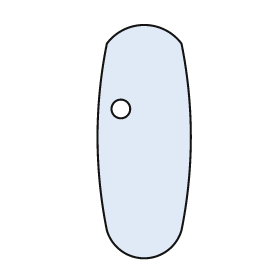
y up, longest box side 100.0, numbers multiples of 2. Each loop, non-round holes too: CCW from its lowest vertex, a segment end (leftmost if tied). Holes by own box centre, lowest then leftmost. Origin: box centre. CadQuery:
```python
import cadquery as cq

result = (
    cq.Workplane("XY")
    .moveTo(-16.0, -38.0)
    .threePointArc((0.0, -50.0), (16.0, -38.0))
    .threePointArc((20.0, 2.0), (16.0, 42.0))
    .threePointArc((0.0, 50.0), (-16.0, 42.0))
    .threePointArc((-20.0, 2.0), (-16.0, -38.0))
    .close()
    .moveTo(-10.0, 14.0)
    .circle(4.0)
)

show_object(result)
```